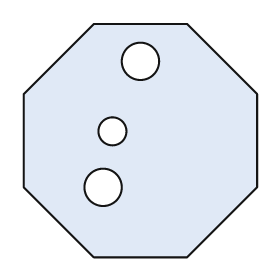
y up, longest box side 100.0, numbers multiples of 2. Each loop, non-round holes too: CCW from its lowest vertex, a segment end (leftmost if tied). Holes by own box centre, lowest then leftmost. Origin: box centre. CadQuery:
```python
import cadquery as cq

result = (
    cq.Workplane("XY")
    .moveTo(-20.0, -50.0)
    .lineTo(20.0, -50.0)
    .lineTo(50.0, -20.0)
    .lineTo(50.0, 20.0)
    .lineTo(20.0, 50.0)
    .lineTo(-20.0, 50.0)
    .lineTo(-50.0, 20.0)
    .lineTo(-50.0, -20.0)
    .close()
    .moveTo(-16.0, -20.0)
    .circle(8.0)
    .moveTo(-12.0, 4.0)
    .circle(6.0)
    .moveTo(0.0, 34.0)
    .circle(8.0)
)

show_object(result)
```